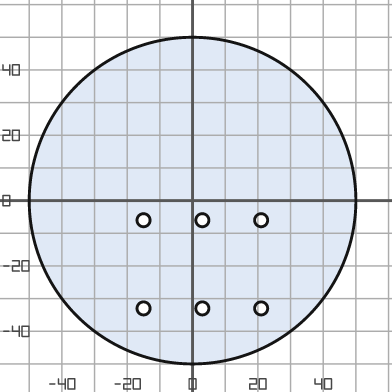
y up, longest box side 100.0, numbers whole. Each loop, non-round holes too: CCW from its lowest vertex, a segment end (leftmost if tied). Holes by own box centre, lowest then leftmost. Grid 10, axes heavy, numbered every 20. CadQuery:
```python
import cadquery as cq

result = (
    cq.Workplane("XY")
    .moveTo(0.0, 0.0)
    .circle(50.0)
    .moveTo(-15.0, -33.0)
    .circle(2.0)
    .moveTo(3.0, -33.0)
    .circle(2.0)
    .moveTo(21.0, -33.0)
    .circle(2.0)
    .moveTo(-15.0, -6.0)
    .circle(2.0)
    .moveTo(3.0, -6.0)
    .circle(2.0)
    .moveTo(21.0, -6.0)
    .circle(2.0)
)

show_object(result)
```